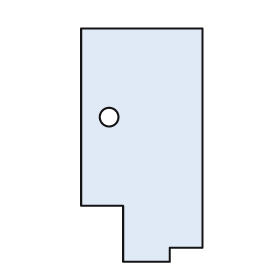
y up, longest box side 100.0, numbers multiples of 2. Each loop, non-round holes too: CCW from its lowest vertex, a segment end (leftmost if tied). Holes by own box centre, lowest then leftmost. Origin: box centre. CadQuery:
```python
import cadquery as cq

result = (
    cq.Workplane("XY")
    .moveTo(-8.0, -50.0)
    .lineTo(12.0, -50.0)
    .lineTo(12.0, -44.0)
    .lineTo(26.0, -44.0)
    .lineTo(26.0, 50.0)
    .lineTo(-26.0, 50.0)
    .lineTo(-26.0, -26.0)
    .lineTo(-8.0, -26.0)
    .close()
    .moveTo(-14.0, 12.0)
    .circle(4.0)
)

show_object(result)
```